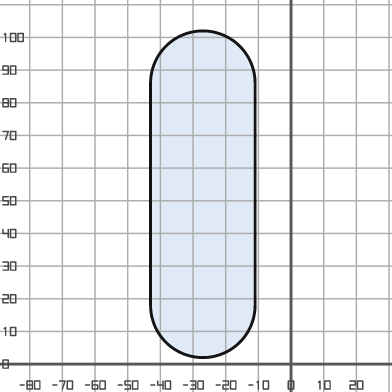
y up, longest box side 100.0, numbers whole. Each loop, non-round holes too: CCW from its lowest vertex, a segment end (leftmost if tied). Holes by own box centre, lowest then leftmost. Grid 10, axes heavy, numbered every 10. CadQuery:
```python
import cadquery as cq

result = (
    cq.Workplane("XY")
    .moveTo(-43.0, 18.0)
    .threePointArc((-27.0, 2.0), (-11.0, 18.0))
    .lineTo(-11.0, 86.0)
    .threePointArc((-27.0, 102.0), (-43.0, 86.0))
    .close()
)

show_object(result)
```